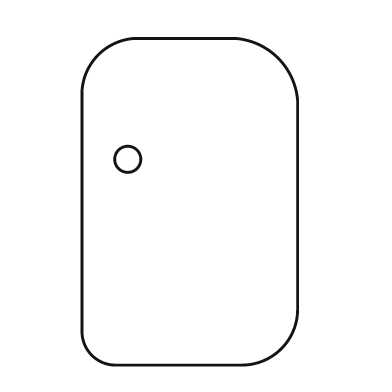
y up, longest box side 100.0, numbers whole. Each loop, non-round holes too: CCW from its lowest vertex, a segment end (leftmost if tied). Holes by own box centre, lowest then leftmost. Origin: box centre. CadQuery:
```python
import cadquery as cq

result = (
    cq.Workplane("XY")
    .moveTo(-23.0, -50.0)
    .lineTo(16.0, -50.0)
    .threePointArc((28.0, -45.0), (33.0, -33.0))
    .lineTo(33.0, 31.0)
    .threePointArc((27.0, 44.0), (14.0, 50.0))
    .lineTo(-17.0, 50.0)
    .threePointArc((-28.0, 45.0), (-33.0, 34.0))
    .lineTo(-33.0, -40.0)
    .threePointArc((-30.0, -47.0), (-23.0, -50.0))
    .close()
    .moveTo(-19.0, 13.0)
    .circle(4.0)
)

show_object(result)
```